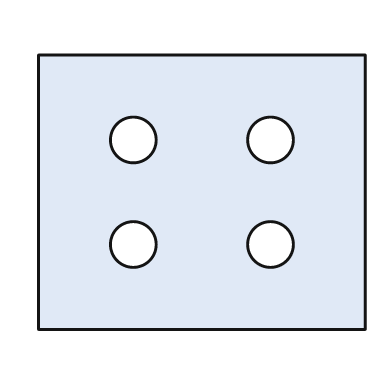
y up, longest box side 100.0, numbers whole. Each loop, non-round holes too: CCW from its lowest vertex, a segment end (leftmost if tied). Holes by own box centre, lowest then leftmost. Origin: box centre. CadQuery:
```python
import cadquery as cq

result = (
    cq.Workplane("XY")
    .moveTo(-50.0, -42.0)
    .lineTo(50.0, -42.0)
    .lineTo(50.0, 42.0)
    .lineTo(-50.0, 42.0)
    .close()
    .moveTo(-21.0, -16.0)
    .circle(7.0)
    .moveTo(21.0, -16.0)
    .circle(7.0)
    .moveTo(-21.0, 16.0)
    .circle(7.0)
    .moveTo(21.0, 16.0)
    .circle(7.0)
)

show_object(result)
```